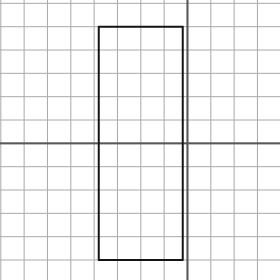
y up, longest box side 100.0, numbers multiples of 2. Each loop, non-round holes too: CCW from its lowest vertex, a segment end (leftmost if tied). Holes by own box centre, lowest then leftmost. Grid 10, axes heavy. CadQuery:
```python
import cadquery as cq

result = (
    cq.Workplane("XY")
    .moveTo(-38.0, -50.0)
    .lineTo(-2.0, -50.0)
    .lineTo(-2.0, 50.0)
    .lineTo(-38.0, 50.0)
    .close()
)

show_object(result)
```